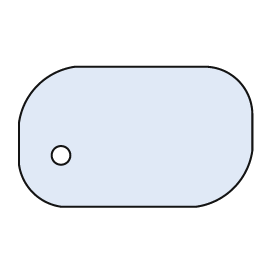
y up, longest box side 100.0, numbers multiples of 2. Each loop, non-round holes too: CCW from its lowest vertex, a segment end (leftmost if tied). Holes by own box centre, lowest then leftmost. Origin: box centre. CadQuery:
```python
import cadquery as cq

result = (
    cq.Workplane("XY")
    .moveTo(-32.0, -30.0)
    .lineTo(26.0, -30.0)
    .threePointArc((42.0, -22.0), (50.0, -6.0))
    .lineTo(50.0, 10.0)
    .threePointArc((44.0, 24.0), (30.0, 30.0))
    .lineTo(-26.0, 30.0)
    .threePointArc((-42.0, 22.0), (-50.0, 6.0))
    .lineTo(-50.0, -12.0)
    .threePointArc((-44.0, -24.0), (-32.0, -30.0))
    .close()
    .moveTo(-32.0, -8.0)
    .circle(4.0)
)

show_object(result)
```